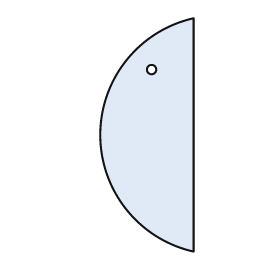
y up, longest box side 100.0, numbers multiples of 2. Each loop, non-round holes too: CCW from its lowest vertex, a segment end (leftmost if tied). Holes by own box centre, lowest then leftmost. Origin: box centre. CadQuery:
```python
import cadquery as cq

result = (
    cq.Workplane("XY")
    .moveTo(20.0, -50.0)
    .lineTo(20.0, 50.0)
    .threePointArc((-20.0, 0.0), (20.0, -50.0))
    .close()
    .moveTo(2.0, 28.0)
    .circle(2.0)
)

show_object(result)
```